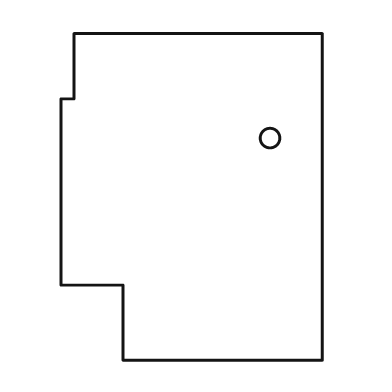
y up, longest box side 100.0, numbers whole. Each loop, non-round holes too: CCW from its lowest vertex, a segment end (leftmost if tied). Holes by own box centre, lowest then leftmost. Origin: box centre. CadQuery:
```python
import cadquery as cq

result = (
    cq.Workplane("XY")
    .moveTo(-21.0, -50.0)
    .lineTo(40.0, -50.0)
    .lineTo(40.0, 50.0)
    .lineTo(-36.0, 50.0)
    .lineTo(-36.0, 30.0)
    .lineTo(-40.0, 30.0)
    .lineTo(-40.0, -27.0)
    .lineTo(-21.0, -27.0)
    .close()
    .moveTo(24.0, 18.0)
    .circle(3.0)
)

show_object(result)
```